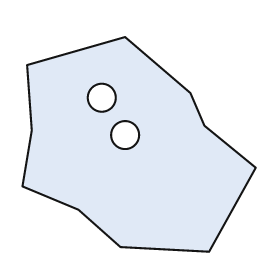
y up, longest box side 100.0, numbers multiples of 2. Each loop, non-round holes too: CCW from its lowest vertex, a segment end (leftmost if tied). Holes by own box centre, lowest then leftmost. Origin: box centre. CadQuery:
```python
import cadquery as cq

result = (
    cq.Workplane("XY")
    .moveTo(30.0, -46.0)
    .lineTo(50.0, -10.0)
    .lineTo(28.0, 8.0)
    .lineTo(22.0, 22.0)
    .lineTo(-6.0, 46.0)
    .lineTo(-48.0, 34.0)
    .lineTo(-46.0, 6.0)
    .lineTo(-50.0, -18.0)
    .lineTo(-26.0, -28.0)
    .lineTo(-8.0, -44.0)
    .close()
    .moveTo(-6.0, 4.0)
    .circle(6.0)
    .moveTo(-16.0, 20.0)
    .circle(6.0)
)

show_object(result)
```